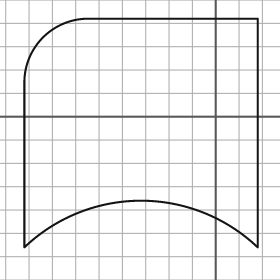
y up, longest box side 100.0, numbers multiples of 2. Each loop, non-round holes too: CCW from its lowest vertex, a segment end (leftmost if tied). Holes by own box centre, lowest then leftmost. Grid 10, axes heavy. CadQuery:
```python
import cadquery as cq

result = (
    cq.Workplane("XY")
    .moveTo(-82.0, -56.0)
    .threePointArc((-32.0, -36.0), (18.0, -56.0))
    .lineTo(18.0, 42.0)
    .lineTo(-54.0, 42.0)
    .threePointArc((-74.0, 34.0), (-82.0, 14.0))
    .close()
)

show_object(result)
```